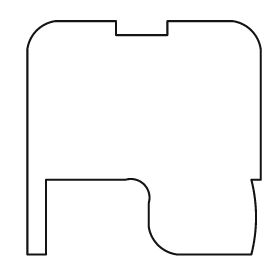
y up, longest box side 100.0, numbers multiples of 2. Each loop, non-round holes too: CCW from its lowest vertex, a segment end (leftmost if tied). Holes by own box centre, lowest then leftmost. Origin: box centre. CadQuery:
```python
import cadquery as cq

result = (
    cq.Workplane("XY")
    .moveTo(-50.0, -50.0)
    .lineTo(-42.0, -50.0)
    .lineTo(-42.0, -18.0)
    .lineTo(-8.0, -18.0)
    .threePointArc((0.0, -20.0), (2.0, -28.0))
    .lineTo(2.0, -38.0)
    .threePointArc((6.0, -46.0), (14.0, -50.0))
    .lineTo(46.0, -50.0)
    .threePointArc((48.0, -34.0), (46.0, -18.0))
    .lineTo(50.0, -18.0)
    .lineTo(50.0, 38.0)
    .threePointArc((46.0, 46.0), (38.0, 50.0))
    .lineTo(10.0, 50.0)
    .lineTo(10.0, 44.0)
    .lineTo(-12.0, 44.0)
    .lineTo(-12.0, 50.0)
    .lineTo(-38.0, 50.0)
    .threePointArc((-46.0, 46.0), (-50.0, 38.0))
    .close()
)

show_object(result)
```